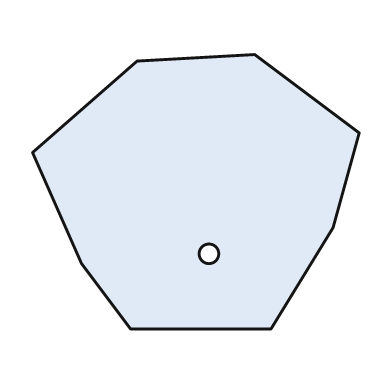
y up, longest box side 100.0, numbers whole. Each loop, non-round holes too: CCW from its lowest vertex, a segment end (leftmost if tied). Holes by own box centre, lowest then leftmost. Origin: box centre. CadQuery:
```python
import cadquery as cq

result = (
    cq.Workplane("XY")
    .moveTo(-20.0, -42.0)
    .lineTo(23.0, -42.0)
    .lineTo(42.0, -11.0)
    .lineTo(50.0, 18.0)
    .lineTo(18.0, 42.0)
    .lineTo(-18.0, 40.0)
    .lineTo(-50.0, 12.0)
    .lineTo(-35.0, -22.0)
    .close()
    .moveTo(4.0, -19.0)
    .circle(3.0)
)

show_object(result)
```